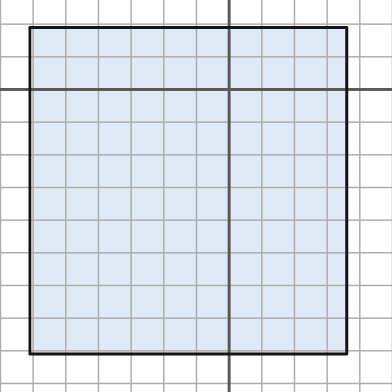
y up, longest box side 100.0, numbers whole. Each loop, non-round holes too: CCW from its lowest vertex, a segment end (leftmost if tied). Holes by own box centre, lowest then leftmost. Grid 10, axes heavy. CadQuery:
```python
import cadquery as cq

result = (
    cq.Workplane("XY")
    .moveTo(-61.0, -81.0)
    .lineTo(36.0, -81.0)
    .lineTo(36.0, 19.0)
    .lineTo(-61.0, 19.0)
    .close()
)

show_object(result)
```